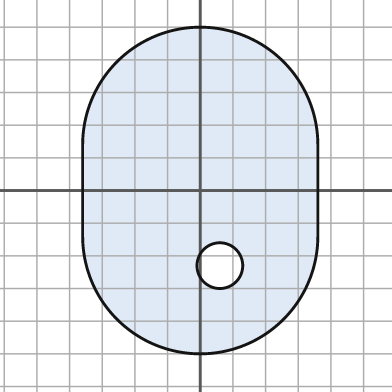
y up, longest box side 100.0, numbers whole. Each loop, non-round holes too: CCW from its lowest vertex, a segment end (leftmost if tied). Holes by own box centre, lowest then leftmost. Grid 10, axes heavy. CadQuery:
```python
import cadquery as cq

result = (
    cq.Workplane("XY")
    .moveTo(-36.0, -14.0)
    .threePointArc((0.0, -50.0), (36.0, -14.0))
    .lineTo(36.0, 14.0)
    .threePointArc((0.0, 50.0), (-36.0, 14.0))
    .close()
    .moveTo(6.0, -23.0)
    .circle(7.0)
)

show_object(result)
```